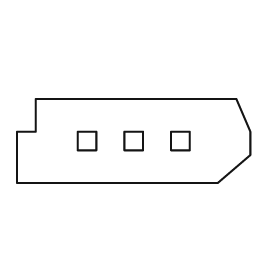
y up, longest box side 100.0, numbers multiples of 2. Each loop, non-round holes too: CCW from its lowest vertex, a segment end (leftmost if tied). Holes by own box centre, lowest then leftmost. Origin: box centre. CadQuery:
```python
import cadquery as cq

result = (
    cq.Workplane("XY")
    .moveTo(-50.0, -18.0)
    .lineTo(36.0, -18.0)
    .lineTo(50.0, -6.0)
    .lineTo(50.0, 4.0)
    .lineTo(44.0, 18.0)
    .lineTo(-42.0, 18.0)
    .lineTo(-42.0, 4.0)
    .lineTo(-50.0, 4.0)
    .close()
    .moveTo(-24.0, -4.0)
    .lineTo(-16.0, -4.0)
    .lineTo(-16.0, 4.0)
    .lineTo(-24.0, 4.0)
    .close()
    .moveTo(-4.0, -4.0)
    .lineTo(4.0, -4.0)
    .lineTo(4.0, 4.0)
    .lineTo(-4.0, 4.0)
    .close()
    .moveTo(16.0, -4.0)
    .lineTo(24.0, -4.0)
    .lineTo(24.0, 4.0)
    .lineTo(16.0, 4.0)
    .close()
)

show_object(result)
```